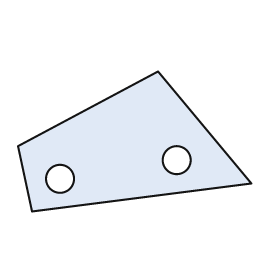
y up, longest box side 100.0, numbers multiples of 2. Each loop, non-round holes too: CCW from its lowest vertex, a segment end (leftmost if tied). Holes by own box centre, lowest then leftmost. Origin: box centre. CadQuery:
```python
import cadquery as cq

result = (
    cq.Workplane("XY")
    .moveTo(-44.0, -30.0)
    .lineTo(50.0, -18.0)
    .lineTo(10.0, 30.0)
    .lineTo(-50.0, -2.0)
    .close()
    .moveTo(-32.0, -16.0)
    .circle(6.0)
    .moveTo(18.0, -8.0)
    .circle(6.0)
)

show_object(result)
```